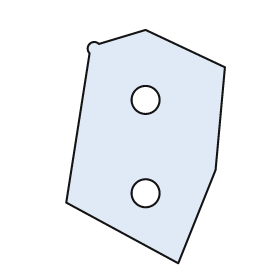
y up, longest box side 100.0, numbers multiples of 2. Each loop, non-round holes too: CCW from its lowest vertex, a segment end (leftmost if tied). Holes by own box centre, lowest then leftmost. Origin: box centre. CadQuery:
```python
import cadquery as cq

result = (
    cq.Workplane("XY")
    .moveTo(14.0, -50.0)
    .lineTo(30.0, -10.0)
    .lineTo(34.0, 34.0)
    .lineTo(0.0, 50.0)
    .lineTo(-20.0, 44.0)
    .threePointArc((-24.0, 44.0), (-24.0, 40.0))
    .lineTo(-34.0, -24.0)
    .close()
    .moveTo(0.0, -20.0)
    .circle(6.0)
    .moveTo(0.0, 20.0)
    .circle(6.0)
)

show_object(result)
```